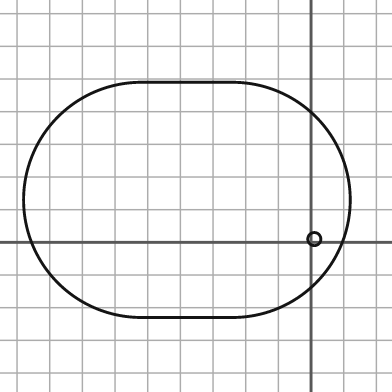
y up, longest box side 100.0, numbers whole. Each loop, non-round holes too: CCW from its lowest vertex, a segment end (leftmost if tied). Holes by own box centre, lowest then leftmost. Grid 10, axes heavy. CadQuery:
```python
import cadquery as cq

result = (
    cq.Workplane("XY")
    .moveTo(-52.0, -23.0)
    .lineTo(-24.0, -23.0)
    .threePointArc((12.0, 13.0), (-24.0, 49.0))
    .lineTo(-52.0, 49.0)
    .threePointArc((-88.0, 13.0), (-52.0, -23.0))
    .close()
    .moveTo(1.0, 1.0)
    .circle(2.0)
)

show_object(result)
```